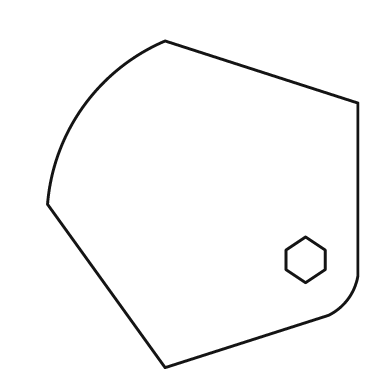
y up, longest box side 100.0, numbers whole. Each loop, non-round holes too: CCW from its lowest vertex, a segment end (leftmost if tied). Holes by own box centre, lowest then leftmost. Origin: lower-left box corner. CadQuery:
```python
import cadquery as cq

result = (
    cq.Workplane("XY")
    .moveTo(36.0, 0.0)
    .lineTo(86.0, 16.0)
    .threePointArc((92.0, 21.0), (95.0, 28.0))
    .lineTo(95.0, 81.0)
    .lineTo(36.0, 100.0)
    .threePointArc((11.0, 80.0), (0.0, 50.0))
    .close()
    .moveTo(79.0, 26.0)
    .lineTo(85.0, 30.0)
    .lineTo(85.0, 36.0)
    .lineTo(79.0, 40.0)
    .lineTo(73.0, 36.0)
    .lineTo(73.0, 30.0)
    .close()
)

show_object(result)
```